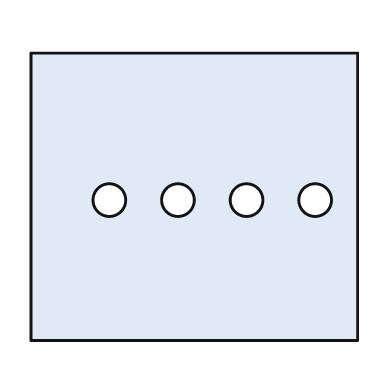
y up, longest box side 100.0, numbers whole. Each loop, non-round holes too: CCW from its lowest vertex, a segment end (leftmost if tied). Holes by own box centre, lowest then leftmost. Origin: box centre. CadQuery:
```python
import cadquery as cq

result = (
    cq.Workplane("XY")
    .moveTo(-50.0, -44.0)
    .lineTo(50.0, -44.0)
    .lineTo(50.0, 44.0)
    .lineTo(-50.0, 44.0)
    .close()
    .moveTo(-26.0, -1.0)
    .circle(5.0)
    .moveTo(-5.0, -1.0)
    .circle(5.0)
    .moveTo(16.0, -1.0)
    .circle(5.0)
    .moveTo(37.0, -1.0)
    .circle(5.0)
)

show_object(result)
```